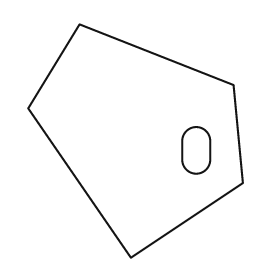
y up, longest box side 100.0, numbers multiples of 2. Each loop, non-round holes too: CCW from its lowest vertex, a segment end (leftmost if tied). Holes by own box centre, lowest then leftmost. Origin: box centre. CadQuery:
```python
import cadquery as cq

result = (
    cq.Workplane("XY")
    .moveTo(-2.0, -50.0)
    .lineTo(46.0, -18.0)
    .lineTo(42.0, 24.0)
    .lineTo(-24.0, 50.0)
    .lineTo(-46.0, 14.0)
    .close()
    .moveTo(20.0, -8.0)
    .threePointArc((26.0, -14.0), (32.0, -8.0))
    .lineTo(32.0, 0.0)
    .threePointArc((26.0, 6.0), (20.0, 0.0))
    .close()
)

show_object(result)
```